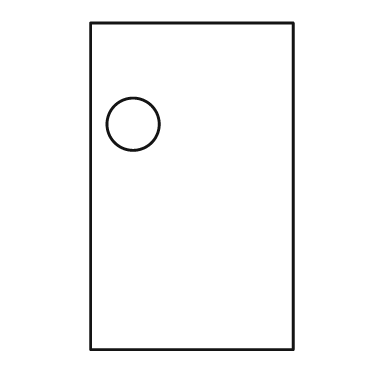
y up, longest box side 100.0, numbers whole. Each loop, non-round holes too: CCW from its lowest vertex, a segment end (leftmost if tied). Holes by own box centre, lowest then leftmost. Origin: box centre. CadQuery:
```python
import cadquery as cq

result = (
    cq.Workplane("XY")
    .moveTo(-31.0, -50.0)
    .lineTo(31.0, -50.0)
    .lineTo(31.0, 50.0)
    .lineTo(-31.0, 50.0)
    .close()
    .moveTo(-18.0, 19.0)
    .circle(8.0)
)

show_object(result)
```